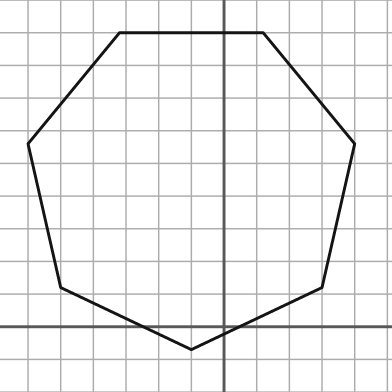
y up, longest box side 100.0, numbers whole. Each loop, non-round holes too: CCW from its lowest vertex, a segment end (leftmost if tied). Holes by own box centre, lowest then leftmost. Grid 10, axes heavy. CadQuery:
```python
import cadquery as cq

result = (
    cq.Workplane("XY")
    .moveTo(-10.0, -7.0)
    .lineTo(30.0, 12.0)
    .lineTo(40.0, 56.0)
    .lineTo(12.0, 90.0)
    .lineTo(-32.0, 90.0)
    .lineTo(-60.0, 56.0)
    .lineTo(-50.0, 12.0)
    .close()
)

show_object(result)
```